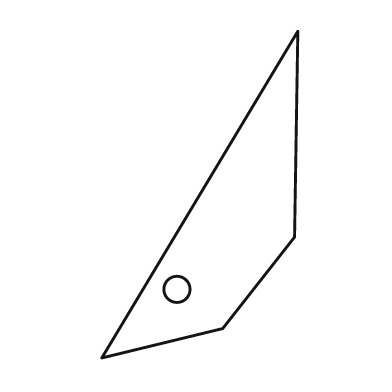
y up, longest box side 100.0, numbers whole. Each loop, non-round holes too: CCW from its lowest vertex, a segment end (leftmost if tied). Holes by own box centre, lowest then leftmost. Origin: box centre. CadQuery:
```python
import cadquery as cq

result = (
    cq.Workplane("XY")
    .moveTo(-30.0, -50.0)
    .lineTo(7.0, -41.0)
    .lineTo(29.0, -13.0)
    .lineTo(30.0, 50.0)
    .close()
    .moveTo(-7.0, -29.0)
    .circle(4.0)
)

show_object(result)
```